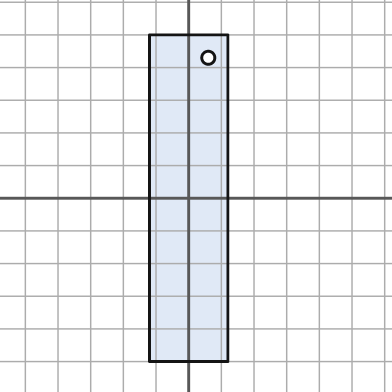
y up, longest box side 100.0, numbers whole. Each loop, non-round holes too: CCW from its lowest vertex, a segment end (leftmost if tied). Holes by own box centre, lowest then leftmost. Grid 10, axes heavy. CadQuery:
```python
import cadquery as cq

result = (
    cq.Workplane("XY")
    .moveTo(-12.0, -50.0)
    .lineTo(12.0, -50.0)
    .lineTo(12.0, 50.0)
    .lineTo(-12.0, 50.0)
    .close()
    .moveTo(6.0, 43.0)
    .circle(2.0)
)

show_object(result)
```